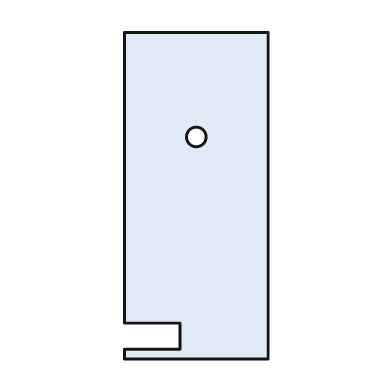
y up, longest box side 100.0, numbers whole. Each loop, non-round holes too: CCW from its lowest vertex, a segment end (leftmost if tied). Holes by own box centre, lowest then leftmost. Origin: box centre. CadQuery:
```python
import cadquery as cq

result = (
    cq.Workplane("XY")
    .moveTo(-22.0, -50.0)
    .lineTo(22.0, -50.0)
    .lineTo(22.0, 50.0)
    .lineTo(-22.0, 50.0)
    .lineTo(-22.0, -39.0)
    .lineTo(-5.0, -39.0)
    .lineTo(-5.0, -47.0)
    .lineTo(-22.0, -47.0)
    .close()
    .moveTo(0.0, 18.0)
    .circle(3.0)
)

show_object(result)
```